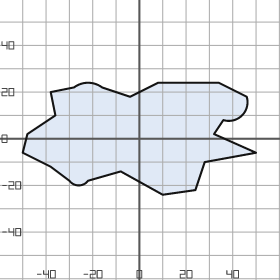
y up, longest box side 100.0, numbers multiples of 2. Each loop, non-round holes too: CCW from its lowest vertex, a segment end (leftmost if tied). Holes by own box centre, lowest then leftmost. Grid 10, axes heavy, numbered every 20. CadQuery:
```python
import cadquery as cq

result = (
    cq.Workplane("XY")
    .moveTo(10.0, -24.0)
    .lineTo(24.0, -22.0)
    .lineTo(28.0, -10.0)
    .lineTo(50.0, -6.0)
    .lineTo(32.0, 2.0)
    .lineTo(36.0, 8.0)
    .threePointArc((44.0, 10.0), (46.0, 18.0))
    .lineTo(34.0, 24.0)
    .lineTo(8.0, 24.0)
    .lineTo(-4.0, 18.0)
    .lineTo(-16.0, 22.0)
    .threePointArc((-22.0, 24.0), (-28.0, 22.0))
    .lineTo(-38.0, 20.0)
    .lineTo(-36.0, 10.0)
    .lineTo(-48.0, 2.0)
    .lineTo(-50.0, -6.0)
    .lineTo(-38.0, -12.0)
    .lineTo(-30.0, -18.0)
    .threePointArc((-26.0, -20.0), (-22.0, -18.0))
    .lineTo(-8.0, -14.0)
    .close()
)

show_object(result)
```